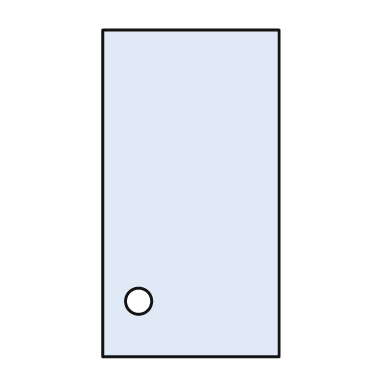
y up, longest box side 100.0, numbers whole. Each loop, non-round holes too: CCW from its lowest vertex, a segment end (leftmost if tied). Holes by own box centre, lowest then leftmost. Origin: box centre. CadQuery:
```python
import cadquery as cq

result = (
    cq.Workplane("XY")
    .moveTo(-27.0, -50.0)
    .lineTo(27.0, -50.0)
    .lineTo(27.0, 50.0)
    .lineTo(-27.0, 50.0)
    .close()
    .moveTo(-16.0, -33.0)
    .circle(4.0)
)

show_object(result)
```